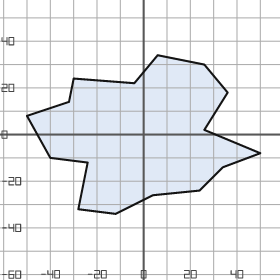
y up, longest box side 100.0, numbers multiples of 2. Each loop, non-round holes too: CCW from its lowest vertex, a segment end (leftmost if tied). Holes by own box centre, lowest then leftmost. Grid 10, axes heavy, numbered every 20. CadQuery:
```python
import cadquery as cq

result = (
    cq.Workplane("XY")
    .moveTo(-12.0, -34.0)
    .lineTo(4.0, -26.0)
    .lineTo(24.0, -24.0)
    .lineTo(34.0, -14.0)
    .lineTo(50.0, -8.0)
    .lineTo(26.0, 2.0)
    .lineTo(36.0, 18.0)
    .lineTo(26.0, 30.0)
    .lineTo(6.0, 34.0)
    .lineTo(-4.0, 22.0)
    .lineTo(-30.0, 24.0)
    .lineTo(-32.0, 14.0)
    .lineTo(-50.0, 8.0)
    .lineTo(-40.0, -10.0)
    .lineTo(-24.0, -12.0)
    .lineTo(-28.0, -32.0)
    .close()
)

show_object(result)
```